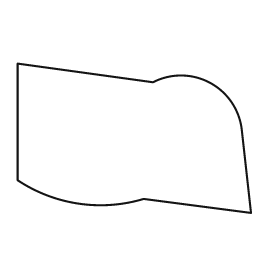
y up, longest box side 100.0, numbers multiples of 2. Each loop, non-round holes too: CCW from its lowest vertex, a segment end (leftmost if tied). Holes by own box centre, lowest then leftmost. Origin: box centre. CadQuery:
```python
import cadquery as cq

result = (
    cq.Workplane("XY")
    .moveTo(50.0, -32.0)
    .lineTo(46.0, 4.0)
    .threePointArc((32.0, 24.0), (8.0, 24.0))
    .lineTo(-50.0, 32.0)
    .lineTo(-50.0, -18.0)
    .threePointArc((-24.0, -28.0), (4.0, -26.0))
    .close()
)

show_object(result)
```